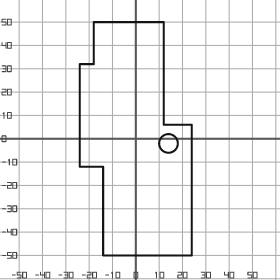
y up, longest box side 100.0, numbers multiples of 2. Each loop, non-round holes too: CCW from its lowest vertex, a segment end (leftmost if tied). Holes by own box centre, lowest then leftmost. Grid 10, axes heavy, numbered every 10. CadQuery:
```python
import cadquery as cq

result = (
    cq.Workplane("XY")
    .moveTo(-14.0, -50.0)
    .lineTo(24.0, -50.0)
    .lineTo(24.0, 6.0)
    .lineTo(12.0, 6.0)
    .lineTo(12.0, 50.0)
    .lineTo(-18.0, 50.0)
    .lineTo(-18.0, 32.0)
    .lineTo(-24.0, 32.0)
    .lineTo(-24.0, -12.0)
    .lineTo(-14.0, -12.0)
    .close()
    .moveTo(14.0, -2.0)
    .circle(4.0)
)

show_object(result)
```